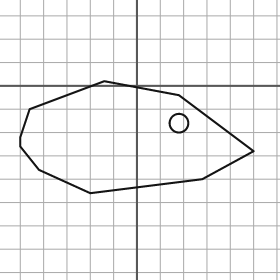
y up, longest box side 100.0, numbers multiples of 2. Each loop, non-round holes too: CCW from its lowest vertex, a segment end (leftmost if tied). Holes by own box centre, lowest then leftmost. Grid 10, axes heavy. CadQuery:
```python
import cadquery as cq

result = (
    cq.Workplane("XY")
    .moveTo(-20.0, -46.0)
    .lineTo(28.0, -40.0)
    .lineTo(50.0, -28.0)
    .lineTo(18.0, -4.0)
    .lineTo(-14.0, 2.0)
    .lineTo(-46.0, -10.0)
    .lineTo(-50.0, -22.0)
    .lineTo(-50.0, -26.0)
    .lineTo(-42.0, -36.0)
    .close()
    .moveTo(18.0, -16.0)
    .circle(4.0)
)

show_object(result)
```